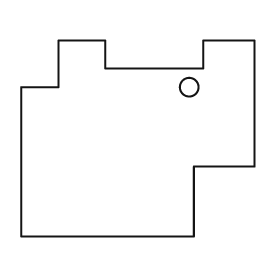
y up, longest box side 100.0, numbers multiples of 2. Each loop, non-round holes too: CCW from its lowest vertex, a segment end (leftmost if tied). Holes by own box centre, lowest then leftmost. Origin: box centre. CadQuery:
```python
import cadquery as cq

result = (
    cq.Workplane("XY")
    .moveTo(-50.0, -42.0)
    .lineTo(24.0, -42.0)
    .lineTo(24.0, -12.0)
    .lineTo(50.0, -12.0)
    .lineTo(50.0, 42.0)
    .lineTo(28.0, 42.0)
    .lineTo(28.0, 30.0)
    .lineTo(-14.0, 30.0)
    .lineTo(-14.0, 42.0)
    .lineTo(-34.0, 42.0)
    .lineTo(-34.0, 22.0)
    .lineTo(-50.0, 22.0)
    .close()
    .moveTo(22.0, 22.0)
    .circle(4.0)
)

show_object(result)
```